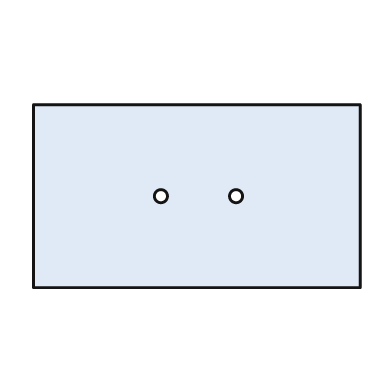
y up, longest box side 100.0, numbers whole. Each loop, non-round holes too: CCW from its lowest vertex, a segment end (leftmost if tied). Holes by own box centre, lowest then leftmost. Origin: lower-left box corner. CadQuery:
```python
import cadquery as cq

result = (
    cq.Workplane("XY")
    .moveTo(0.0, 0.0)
    .lineTo(100.0, 0.0)
    .lineTo(100.0, 56.0)
    .lineTo(0.0, 56.0)
    .close()
    .moveTo(39.0, 28.0)
    .circle(2.0)
    .moveTo(62.0, 28.0)
    .circle(2.0)
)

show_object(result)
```